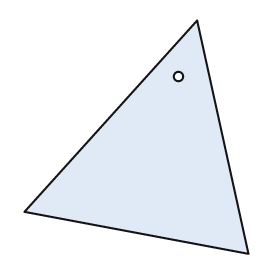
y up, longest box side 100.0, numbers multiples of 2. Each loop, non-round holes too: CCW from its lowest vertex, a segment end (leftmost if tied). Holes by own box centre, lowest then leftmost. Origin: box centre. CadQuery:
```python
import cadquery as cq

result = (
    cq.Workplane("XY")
    .moveTo(48.0, -50.0)
    .lineTo(26.0, 50.0)
    .lineTo(-48.0, -32.0)
    .close()
    .moveTo(18.0, 26.0)
    .circle(2.0)
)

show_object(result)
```